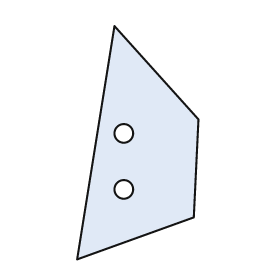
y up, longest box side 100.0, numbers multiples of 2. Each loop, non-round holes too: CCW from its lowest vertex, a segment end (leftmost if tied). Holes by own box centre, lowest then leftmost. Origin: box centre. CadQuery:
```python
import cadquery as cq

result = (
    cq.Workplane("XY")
    .moveTo(-26.0, -50.0)
    .lineTo(24.0, -32.0)
    .lineTo(26.0, 10.0)
    .lineTo(-10.0, 50.0)
    .close()
    .moveTo(-6.0, -20.0)
    .circle(4.0)
    .moveTo(-6.0, 4.0)
    .circle(4.0)
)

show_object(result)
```